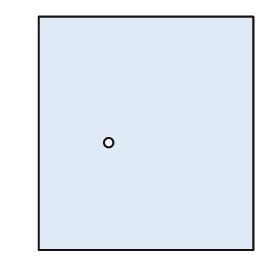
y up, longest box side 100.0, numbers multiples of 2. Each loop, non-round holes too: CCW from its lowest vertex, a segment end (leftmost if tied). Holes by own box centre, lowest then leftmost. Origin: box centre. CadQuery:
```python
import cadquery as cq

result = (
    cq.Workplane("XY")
    .moveTo(-46.0, -50.0)
    .lineTo(46.0, -50.0)
    .lineTo(46.0, 50.0)
    .lineTo(-46.0, 50.0)
    .close()
    .moveTo(-16.0, -4.0)
    .circle(2.0)
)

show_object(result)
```